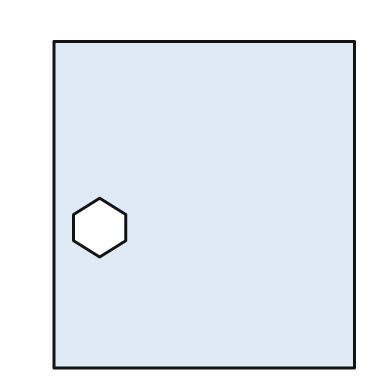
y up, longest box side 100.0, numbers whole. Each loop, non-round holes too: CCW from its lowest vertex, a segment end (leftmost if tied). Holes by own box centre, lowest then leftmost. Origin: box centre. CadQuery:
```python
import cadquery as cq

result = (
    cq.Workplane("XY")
    .moveTo(-46.0, -50.0)
    .lineTo(46.0, -50.0)
    .lineTo(46.0, 50.0)
    .lineTo(-46.0, 50.0)
    .close()
    .moveTo(-32.0, -16.0)
    .lineTo(-24.0, -11.0)
    .lineTo(-24.0, -3.0)
    .lineTo(-32.0, 2.0)
    .lineTo(-40.0, -3.0)
    .lineTo(-40.0, -11.0)
    .close()
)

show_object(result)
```